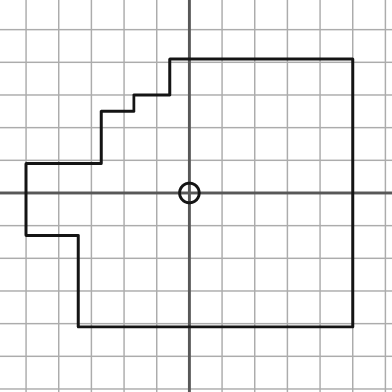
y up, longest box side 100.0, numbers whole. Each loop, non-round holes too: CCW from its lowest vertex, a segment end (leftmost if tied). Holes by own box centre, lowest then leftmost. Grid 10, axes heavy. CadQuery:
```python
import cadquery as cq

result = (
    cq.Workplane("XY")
    .moveTo(-34.0, -41.0)
    .lineTo(50.0, -41.0)
    .lineTo(50.0, 41.0)
    .lineTo(-6.0, 41.0)
    .lineTo(-6.0, 30.0)
    .lineTo(-17.0, 30.0)
    .lineTo(-17.0, 25.0)
    .lineTo(-27.0, 25.0)
    .lineTo(-27.0, 9.0)
    .lineTo(-50.0, 9.0)
    .lineTo(-50.0, -13.0)
    .lineTo(-34.0, -13.0)
    .close()
    .moveTo(0.0, 0.0)
    .circle(3.0)
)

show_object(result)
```